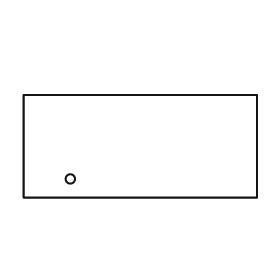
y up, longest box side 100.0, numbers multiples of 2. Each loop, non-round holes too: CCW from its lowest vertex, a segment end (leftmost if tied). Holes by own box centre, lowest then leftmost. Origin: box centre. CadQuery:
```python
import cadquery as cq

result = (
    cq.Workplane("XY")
    .moveTo(-50.0, -22.0)
    .lineTo(50.0, -22.0)
    .lineTo(50.0, 22.0)
    .lineTo(-50.0, 22.0)
    .close()
    .moveTo(-30.0, -14.0)
    .circle(2.0)
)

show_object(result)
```